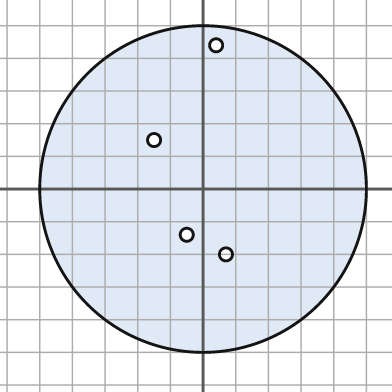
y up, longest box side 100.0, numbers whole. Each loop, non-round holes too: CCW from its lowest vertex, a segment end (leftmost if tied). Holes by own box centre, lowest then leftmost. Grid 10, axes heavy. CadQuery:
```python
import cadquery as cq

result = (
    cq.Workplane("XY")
    .moveTo(0.0, 0.0)
    .circle(50.0)
    .moveTo(7.0, -20.0)
    .circle(2.0)
    .moveTo(-5.0, -14.0)
    .circle(2.0)
    .moveTo(-15.0, 15.0)
    .circle(2.0)
    .moveTo(4.0, 44.0)
    .circle(2.0)
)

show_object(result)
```